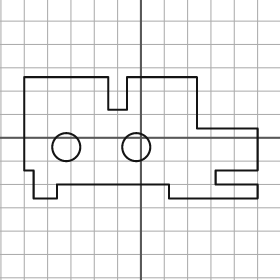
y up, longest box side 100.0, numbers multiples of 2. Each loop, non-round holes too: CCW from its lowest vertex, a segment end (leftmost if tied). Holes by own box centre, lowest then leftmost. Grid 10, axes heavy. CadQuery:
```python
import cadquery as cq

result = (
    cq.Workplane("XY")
    .moveTo(-46.0, -26.0)
    .lineTo(-36.0, -26.0)
    .lineTo(-36.0, -20.0)
    .lineTo(12.0, -20.0)
    .lineTo(12.0, -26.0)
    .lineTo(50.0, -26.0)
    .lineTo(50.0, -20.0)
    .lineTo(32.0, -20.0)
    .lineTo(32.0, -14.0)
    .lineTo(50.0, -14.0)
    .lineTo(50.0, 4.0)
    .lineTo(24.0, 4.0)
    .lineTo(24.0, 26.0)
    .lineTo(-6.0, 26.0)
    .lineTo(-6.0, 12.0)
    .lineTo(-14.0, 12.0)
    .lineTo(-14.0, 26.0)
    .lineTo(-50.0, 26.0)
    .lineTo(-50.0, -14.0)
    .lineTo(-46.0, -14.0)
    .close()
    .moveTo(-32.0, -4.0)
    .circle(6.0)
    .moveTo(-2.0, -4.0)
    .circle(6.0)
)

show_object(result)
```